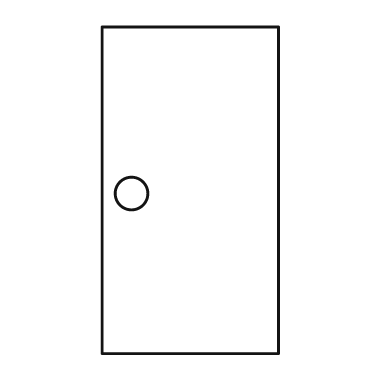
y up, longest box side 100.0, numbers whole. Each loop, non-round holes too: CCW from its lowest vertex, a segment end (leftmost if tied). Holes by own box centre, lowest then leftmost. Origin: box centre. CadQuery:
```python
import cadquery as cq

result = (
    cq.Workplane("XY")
    .moveTo(-27.0, -50.0)
    .lineTo(27.0, -50.0)
    .lineTo(27.0, 50.0)
    .lineTo(-27.0, 50.0)
    .close()
    .moveTo(-18.0, -1.0)
    .circle(5.0)
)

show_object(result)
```